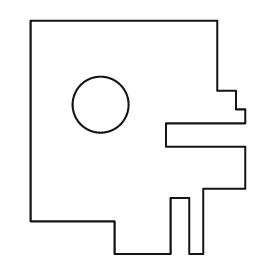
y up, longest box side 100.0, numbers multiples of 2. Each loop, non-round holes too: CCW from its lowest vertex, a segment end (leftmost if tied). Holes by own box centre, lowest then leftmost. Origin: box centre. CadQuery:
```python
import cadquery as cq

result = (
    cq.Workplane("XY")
    .moveTo(-10.0, -50.0)
    .lineTo(14.0, -50.0)
    .lineTo(14.0, -26.0)
    .lineTo(22.0, -26.0)
    .lineTo(22.0, -50.0)
    .lineTo(28.0, -50.0)
    .lineTo(28.0, -22.0)
    .lineTo(46.0, -22.0)
    .lineTo(46.0, -4.0)
    .lineTo(12.0, -4.0)
    .lineTo(12.0, 6.0)
    .lineTo(46.0, 6.0)
    .lineTo(46.0, 12.0)
    .lineTo(42.0, 12.0)
    .lineTo(42.0, 20.0)
    .lineTo(34.0, 20.0)
    .lineTo(34.0, 50.0)
    .lineTo(-46.0, 50.0)
    .lineTo(-46.0, -36.0)
    .lineTo(-10.0, -36.0)
    .close()
    .moveTo(-16.0, 14.0)
    .circle(12.0)
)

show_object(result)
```